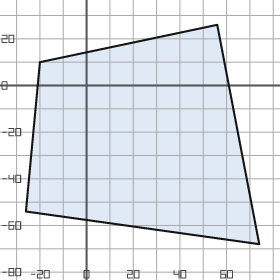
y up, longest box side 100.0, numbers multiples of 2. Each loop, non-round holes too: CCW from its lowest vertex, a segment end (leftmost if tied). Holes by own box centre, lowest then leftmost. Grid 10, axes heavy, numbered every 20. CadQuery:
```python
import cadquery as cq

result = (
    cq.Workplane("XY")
    .moveTo(74.0, -68.0)
    .lineTo(56.0, 26.0)
    .lineTo(-20.0, 10.0)
    .lineTo(-26.0, -54.0)
    .close()
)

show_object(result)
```